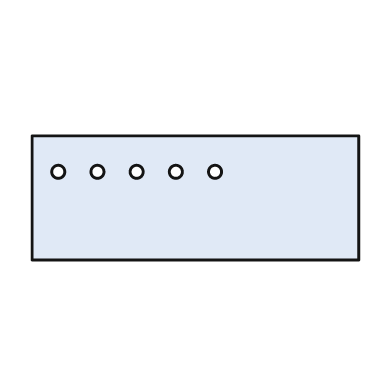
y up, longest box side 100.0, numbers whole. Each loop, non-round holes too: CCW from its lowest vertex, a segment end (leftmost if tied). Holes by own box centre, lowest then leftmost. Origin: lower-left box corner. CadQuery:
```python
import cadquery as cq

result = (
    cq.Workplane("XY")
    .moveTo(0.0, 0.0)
    .lineTo(100.0, 0.0)
    .lineTo(100.0, 38.0)
    .lineTo(0.0, 38.0)
    .close()
    .moveTo(8.0, 27.0)
    .circle(2.0)
    .moveTo(20.0, 27.0)
    .circle(2.0)
    .moveTo(32.0, 27.0)
    .circle(2.0)
    .moveTo(44.0, 27.0)
    .circle(2.0)
    .moveTo(56.0, 27.0)
    .circle(2.0)
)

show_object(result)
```